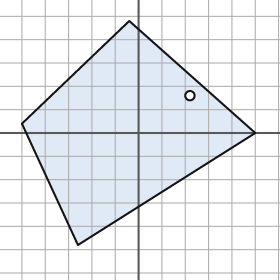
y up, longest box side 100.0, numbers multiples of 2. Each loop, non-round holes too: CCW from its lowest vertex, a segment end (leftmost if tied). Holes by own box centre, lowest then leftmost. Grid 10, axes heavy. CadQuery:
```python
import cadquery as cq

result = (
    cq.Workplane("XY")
    .moveTo(-26.0, -48.0)
    .lineTo(50.0, 0.0)
    .lineTo(-4.0, 48.0)
    .lineTo(-50.0, 4.0)
    .close()
    .moveTo(22.0, 16.0)
    .circle(2.0)
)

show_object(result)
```